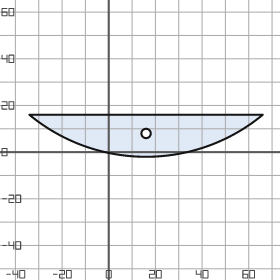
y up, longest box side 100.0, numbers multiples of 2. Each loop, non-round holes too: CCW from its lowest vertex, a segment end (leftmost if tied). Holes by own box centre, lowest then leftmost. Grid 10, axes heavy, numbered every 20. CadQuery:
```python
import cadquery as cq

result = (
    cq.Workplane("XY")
    .moveTo(-34.0, 16.0)
    .threePointArc((16.0, -2.0), (66.0, 16.0))
    .close()
    .moveTo(16.0, 8.0)
    .circle(2.0)
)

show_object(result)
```